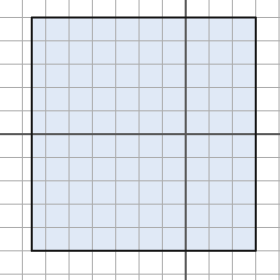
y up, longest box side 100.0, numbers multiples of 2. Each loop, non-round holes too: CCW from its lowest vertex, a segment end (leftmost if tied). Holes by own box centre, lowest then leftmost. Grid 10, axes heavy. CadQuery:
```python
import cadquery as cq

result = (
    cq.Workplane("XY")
    .moveTo(-66.0, -50.0)
    .lineTo(30.0, -50.0)
    .lineTo(30.0, 50.0)
    .lineTo(-66.0, 50.0)
    .close()
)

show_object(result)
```